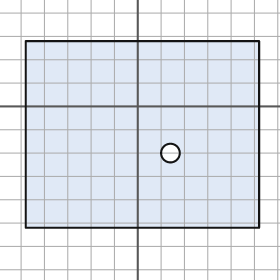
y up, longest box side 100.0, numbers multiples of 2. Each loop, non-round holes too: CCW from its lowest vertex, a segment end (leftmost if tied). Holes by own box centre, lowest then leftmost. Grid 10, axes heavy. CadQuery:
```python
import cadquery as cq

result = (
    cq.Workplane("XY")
    .moveTo(-48.0, -52.0)
    .lineTo(52.0, -52.0)
    .lineTo(52.0, 28.0)
    .lineTo(-48.0, 28.0)
    .close()
    .moveTo(14.0, -20.0)
    .circle(4.0)
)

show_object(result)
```